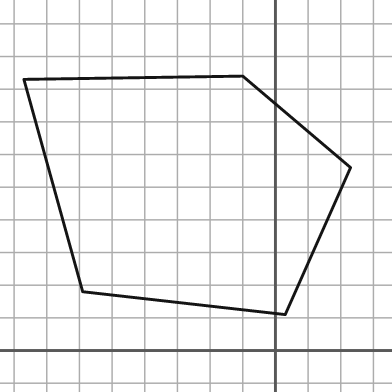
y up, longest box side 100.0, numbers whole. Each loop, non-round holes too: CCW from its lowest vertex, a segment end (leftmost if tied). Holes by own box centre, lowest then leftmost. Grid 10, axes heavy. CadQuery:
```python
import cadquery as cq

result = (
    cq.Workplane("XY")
    .moveTo(3.0, 11.0)
    .lineTo(23.0, 56.0)
    .lineTo(-10.0, 84.0)
    .lineTo(-77.0, 83.0)
    .lineTo(-59.0, 18.0)
    .close()
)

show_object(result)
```